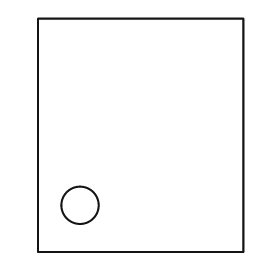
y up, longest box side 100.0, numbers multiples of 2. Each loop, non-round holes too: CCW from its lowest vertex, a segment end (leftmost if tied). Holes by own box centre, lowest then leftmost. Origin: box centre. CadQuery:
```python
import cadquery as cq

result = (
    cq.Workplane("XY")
    .moveTo(-44.0, -50.0)
    .lineTo(44.0, -50.0)
    .lineTo(44.0, 50.0)
    .lineTo(-44.0, 50.0)
    .close()
    .moveTo(-26.0, -30.0)
    .circle(8.0)
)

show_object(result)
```